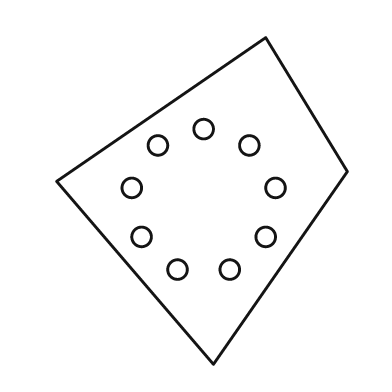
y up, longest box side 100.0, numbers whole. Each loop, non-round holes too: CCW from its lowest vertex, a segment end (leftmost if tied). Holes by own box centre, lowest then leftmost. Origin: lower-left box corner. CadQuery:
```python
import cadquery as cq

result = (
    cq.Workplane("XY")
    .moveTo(48.0, 0.0)
    .lineTo(89.0, 59.0)
    .lineTo(64.0, 100.0)
    .lineTo(0.0, 56.0)
    .close()
    .moveTo(37.0, 29.0)
    .circle(3.0)
    .moveTo(53.0, 29.0)
    .circle(3.0)
    .moveTo(26.0, 39.0)
    .circle(3.0)
    .moveTo(64.0, 39.0)
    .circle(3.0)
    .moveTo(23.0, 54.0)
    .circle(3.0)
    .moveTo(67.0, 54.0)
    .circle(3.0)
    .moveTo(31.0, 67.0)
    .circle(3.0)
    .moveTo(59.0, 67.0)
    .circle(3.0)
    .moveTo(45.0, 72.0)
    .circle(3.0)
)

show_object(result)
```